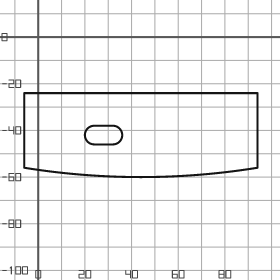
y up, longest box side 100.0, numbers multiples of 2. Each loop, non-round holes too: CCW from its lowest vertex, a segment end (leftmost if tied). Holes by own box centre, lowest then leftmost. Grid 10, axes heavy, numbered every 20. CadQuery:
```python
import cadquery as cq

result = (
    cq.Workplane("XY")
    .moveTo(-6.0, -56.0)
    .threePointArc((44.0, -60.0), (94.0, -56.0))
    .lineTo(94.0, -24.0)
    .lineTo(-6.0, -24.0)
    .close()
    .moveTo(24.0, -46.0)
    .lineTo(32.0, -46.0)
    .threePointArc((36.0, -42.0), (32.0, -38.0))
    .lineTo(24.0, -38.0)
    .threePointArc((20.0, -42.0), (24.0, -46.0))
    .close()
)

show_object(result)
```